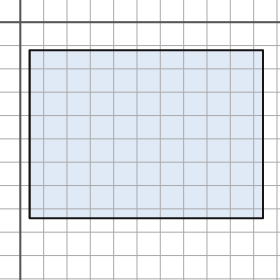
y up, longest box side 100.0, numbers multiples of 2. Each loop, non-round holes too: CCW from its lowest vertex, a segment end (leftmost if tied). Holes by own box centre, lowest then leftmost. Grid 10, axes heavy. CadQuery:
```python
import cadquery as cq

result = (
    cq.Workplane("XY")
    .moveTo(4.0, -84.0)
    .lineTo(104.0, -84.0)
    .lineTo(104.0, -12.0)
    .lineTo(4.0, -12.0)
    .close()
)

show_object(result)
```